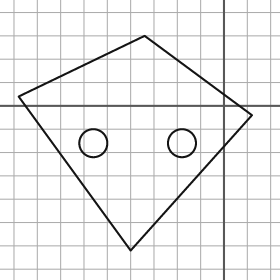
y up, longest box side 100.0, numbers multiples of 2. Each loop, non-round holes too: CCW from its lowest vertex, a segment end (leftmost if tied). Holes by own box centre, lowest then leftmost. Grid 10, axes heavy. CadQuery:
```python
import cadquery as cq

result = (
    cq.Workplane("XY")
    .moveTo(-40.0, -62.0)
    .lineTo(12.0, -4.0)
    .lineTo(-34.0, 30.0)
    .lineTo(-88.0, 4.0)
    .close()
    .moveTo(-56.0, -16.0)
    .circle(6.0)
    .moveTo(-18.0, -16.0)
    .circle(6.0)
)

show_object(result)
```